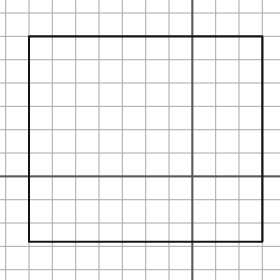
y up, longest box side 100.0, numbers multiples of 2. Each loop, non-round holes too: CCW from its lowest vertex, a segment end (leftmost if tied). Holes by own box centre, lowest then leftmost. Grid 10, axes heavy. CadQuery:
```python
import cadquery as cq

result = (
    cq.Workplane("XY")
    .moveTo(-70.0, -28.0)
    .lineTo(30.0, -28.0)
    .lineTo(30.0, 60.0)
    .lineTo(-70.0, 60.0)
    .close()
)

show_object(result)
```